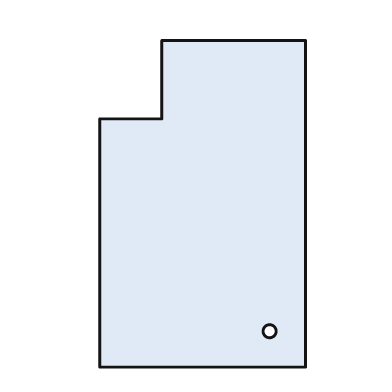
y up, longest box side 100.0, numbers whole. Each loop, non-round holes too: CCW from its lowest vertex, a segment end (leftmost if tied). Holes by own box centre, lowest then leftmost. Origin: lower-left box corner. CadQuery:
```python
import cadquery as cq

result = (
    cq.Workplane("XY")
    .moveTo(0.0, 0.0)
    .lineTo(63.0, 0.0)
    .lineTo(63.0, 100.0)
    .lineTo(19.0, 100.0)
    .lineTo(19.0, 76.0)
    .lineTo(0.0, 76.0)
    .close()
    .moveTo(52.0, 11.0)
    .circle(2.0)
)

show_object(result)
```